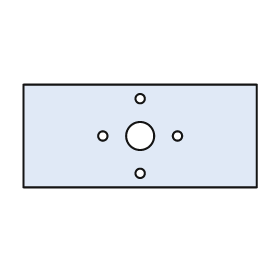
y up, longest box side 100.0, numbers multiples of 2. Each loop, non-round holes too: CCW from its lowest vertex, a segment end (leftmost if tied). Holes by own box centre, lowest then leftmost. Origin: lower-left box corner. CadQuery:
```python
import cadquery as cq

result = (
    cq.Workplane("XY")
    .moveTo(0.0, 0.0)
    .lineTo(100.0, 0.0)
    .lineTo(100.0, 44.0)
    .lineTo(0.0, 44.0)
    .close()
    .moveTo(50.0, 6.0)
    .circle(2.0)
    .moveTo(34.0, 22.0)
    .circle(2.0)
    .moveTo(50.0, 22.0)
    .circle(6.0)
    .moveTo(66.0, 22.0)
    .circle(2.0)
    .moveTo(50.0, 38.0)
    .circle(2.0)
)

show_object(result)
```